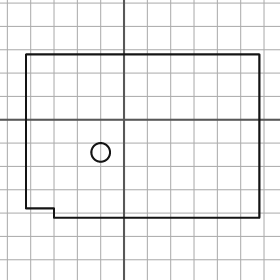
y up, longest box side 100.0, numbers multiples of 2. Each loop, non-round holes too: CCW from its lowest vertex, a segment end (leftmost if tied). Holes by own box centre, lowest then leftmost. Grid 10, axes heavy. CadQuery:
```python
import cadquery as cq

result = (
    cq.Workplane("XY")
    .moveTo(-30.0, -42.0)
    .lineTo(58.0, -42.0)
    .lineTo(58.0, 28.0)
    .lineTo(-42.0, 28.0)
    .lineTo(-42.0, -38.0)
    .lineTo(-30.0, -38.0)
    .close()
    .moveTo(-10.0, -14.0)
    .circle(4.0)
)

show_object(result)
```